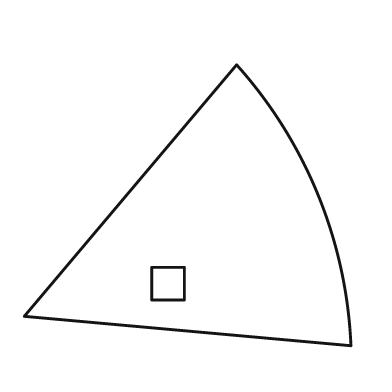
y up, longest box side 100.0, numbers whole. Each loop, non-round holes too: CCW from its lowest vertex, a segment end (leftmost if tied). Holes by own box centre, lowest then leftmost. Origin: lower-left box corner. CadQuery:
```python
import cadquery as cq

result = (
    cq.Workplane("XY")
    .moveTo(100.0, 0.0)
    .threePointArc((90.0, 46.0), (65.0, 86.0))
    .lineTo(0.0, 9.0)
    .close()
    .moveTo(39.0, 14.0)
    .lineTo(49.0, 14.0)
    .lineTo(49.0, 24.0)
    .lineTo(39.0, 24.0)
    .close()
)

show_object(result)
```